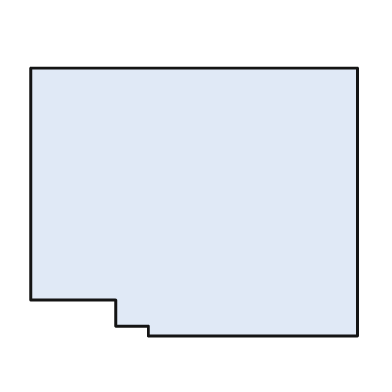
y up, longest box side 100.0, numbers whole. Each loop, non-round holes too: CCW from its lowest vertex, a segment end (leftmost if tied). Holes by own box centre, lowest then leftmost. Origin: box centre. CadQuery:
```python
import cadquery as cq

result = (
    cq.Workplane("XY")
    .moveTo(-14.0, -41.0)
    .lineTo(50.0, -41.0)
    .lineTo(50.0, 41.0)
    .lineTo(-50.0, 41.0)
    .lineTo(-50.0, -30.0)
    .lineTo(-24.0, -30.0)
    .lineTo(-24.0, -38.0)
    .lineTo(-14.0, -38.0)
    .close()
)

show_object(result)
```